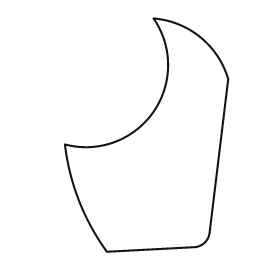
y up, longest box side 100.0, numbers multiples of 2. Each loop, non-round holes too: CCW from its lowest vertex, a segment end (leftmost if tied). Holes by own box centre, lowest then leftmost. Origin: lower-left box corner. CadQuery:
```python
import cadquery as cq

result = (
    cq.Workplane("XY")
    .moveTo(18.0, 0.0)
    .lineTo(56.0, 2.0)
    .threePointArc((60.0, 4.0), (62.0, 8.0))
    .lineTo(70.0, 74.0)
    .threePointArc((58.0, 92.0), (38.0, 100.0))
    .threePointArc((38.0, 60.0), (0.0, 46.0))
    .threePointArc((6.0, 22.0), (18.0, 0.0))
    .close()
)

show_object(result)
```